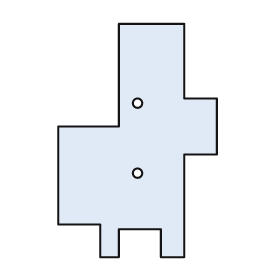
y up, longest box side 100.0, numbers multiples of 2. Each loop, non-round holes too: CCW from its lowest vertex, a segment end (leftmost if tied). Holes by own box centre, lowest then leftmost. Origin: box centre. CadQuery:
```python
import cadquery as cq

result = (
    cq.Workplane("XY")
    .moveTo(-16.0, -50.0)
    .lineTo(-8.0, -50.0)
    .lineTo(-8.0, -38.0)
    .lineTo(10.0, -38.0)
    .lineTo(10.0, -50.0)
    .lineTo(20.0, -50.0)
    .lineTo(20.0, -6.0)
    .lineTo(34.0, -6.0)
    .lineTo(34.0, 18.0)
    .lineTo(20.0, 18.0)
    .lineTo(20.0, 50.0)
    .lineTo(-8.0, 50.0)
    .lineTo(-8.0, 6.0)
    .lineTo(-34.0, 6.0)
    .lineTo(-34.0, -36.0)
    .lineTo(-16.0, -36.0)
    .close()
    .moveTo(0.0, -14.0)
    .circle(2.0)
    .moveTo(0.0, 16.0)
    .circle(2.0)
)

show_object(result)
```